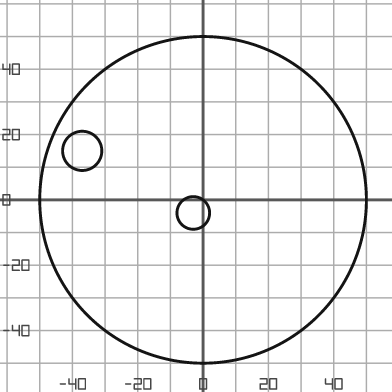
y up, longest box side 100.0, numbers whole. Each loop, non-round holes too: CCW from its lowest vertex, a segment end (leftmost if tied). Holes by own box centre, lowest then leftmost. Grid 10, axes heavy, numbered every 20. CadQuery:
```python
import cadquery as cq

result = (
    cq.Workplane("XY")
    .moveTo(0.0, 0.0)
    .circle(50.0)
    .moveTo(-3.0, -4.0)
    .circle(5.0)
    .moveTo(-37.0, 15.0)
    .circle(6.0)
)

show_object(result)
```